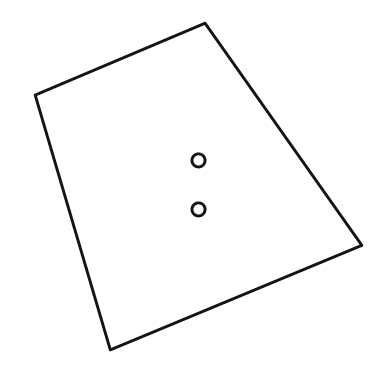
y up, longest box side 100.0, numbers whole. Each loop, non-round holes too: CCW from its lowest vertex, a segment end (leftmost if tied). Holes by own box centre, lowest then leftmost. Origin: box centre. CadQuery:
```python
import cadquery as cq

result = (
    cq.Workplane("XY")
    .moveTo(-27.0, -50.0)
    .lineTo(50.0, -18.0)
    .lineTo(2.0, 50.0)
    .lineTo(-50.0, 28.0)
    .close()
    .moveTo(0.0, -7.0)
    .circle(2.0)
    .moveTo(0.0, 8.0)
    .circle(2.0)
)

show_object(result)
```